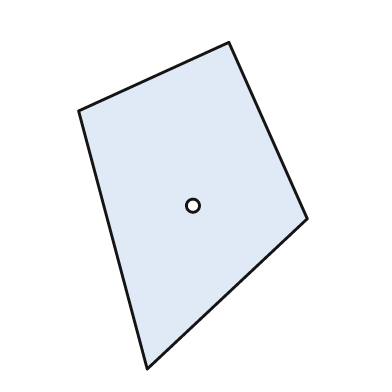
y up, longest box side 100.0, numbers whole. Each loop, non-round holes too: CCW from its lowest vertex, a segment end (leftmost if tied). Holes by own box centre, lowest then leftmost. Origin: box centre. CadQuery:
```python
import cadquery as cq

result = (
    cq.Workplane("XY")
    .moveTo(-14.0, -50.0)
    .lineTo(35.0, -4.0)
    .lineTo(11.0, 50.0)
    .lineTo(-35.0, 29.0)
    .close()
    .moveTo(0.0, 0.0)
    .circle(2.0)
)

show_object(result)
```